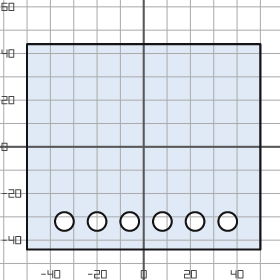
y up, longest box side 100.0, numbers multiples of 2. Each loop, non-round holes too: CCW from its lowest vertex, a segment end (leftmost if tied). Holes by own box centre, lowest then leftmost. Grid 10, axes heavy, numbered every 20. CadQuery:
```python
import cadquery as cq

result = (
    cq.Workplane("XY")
    .moveTo(-50.0, -44.0)
    .lineTo(50.0, -44.0)
    .lineTo(50.0, 44.0)
    .lineTo(-50.0, 44.0)
    .close()
    .moveTo(-34.0, -32.0)
    .circle(4.0)
    .moveTo(-20.0, -32.0)
    .circle(4.0)
    .moveTo(-6.0, -32.0)
    .circle(4.0)
    .moveTo(8.0, -32.0)
    .circle(4.0)
    .moveTo(22.0, -32.0)
    .circle(4.0)
    .moveTo(36.0, -32.0)
    .circle(4.0)
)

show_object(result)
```